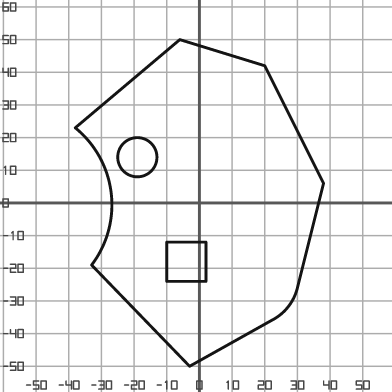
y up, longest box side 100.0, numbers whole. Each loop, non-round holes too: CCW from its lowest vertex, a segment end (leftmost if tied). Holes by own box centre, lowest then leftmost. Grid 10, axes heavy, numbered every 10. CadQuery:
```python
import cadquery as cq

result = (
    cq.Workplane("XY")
    .moveTo(-3.0, -50.0)
    .lineTo(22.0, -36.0)
    .threePointArc((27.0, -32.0), (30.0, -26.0))
    .lineTo(38.0, 6.0)
    .lineTo(20.0, 42.0)
    .lineTo(-6.0, 50.0)
    .lineTo(-38.0, 23.0)
    .threePointArc((-27.0, 3.0), (-33.0, -19.0))
    .close()
    .moveTo(-10.0, -24.0)
    .lineTo(2.0, -24.0)
    .lineTo(2.0, -12.0)
    .lineTo(-10.0, -12.0)
    .close()
    .moveTo(-19.0, 14.0)
    .circle(6.0)
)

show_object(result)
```